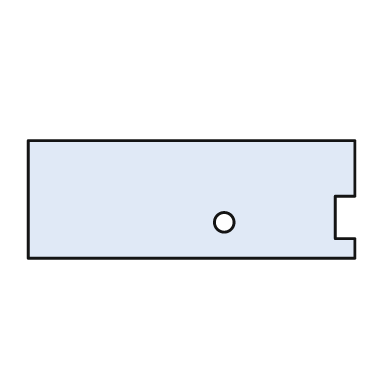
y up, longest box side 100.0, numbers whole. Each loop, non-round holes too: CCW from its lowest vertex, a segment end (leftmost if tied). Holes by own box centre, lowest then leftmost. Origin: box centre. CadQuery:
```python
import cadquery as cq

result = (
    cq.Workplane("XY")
    .moveTo(-50.0, -18.0)
    .lineTo(50.0, -18.0)
    .lineTo(50.0, -12.0)
    .lineTo(44.0, -12.0)
    .lineTo(44.0, 1.0)
    .lineTo(50.0, 1.0)
    .lineTo(50.0, 18.0)
    .lineTo(-50.0, 18.0)
    .close()
    .moveTo(10.0, -7.0)
    .circle(3.0)
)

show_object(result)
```